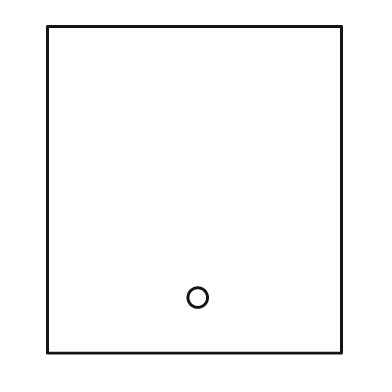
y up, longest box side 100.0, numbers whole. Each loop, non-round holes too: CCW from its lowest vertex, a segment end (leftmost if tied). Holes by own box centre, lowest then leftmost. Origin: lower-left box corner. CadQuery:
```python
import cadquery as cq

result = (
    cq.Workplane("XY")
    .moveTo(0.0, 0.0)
    .lineTo(90.0, 0.0)
    .lineTo(90.0, 100.0)
    .lineTo(0.0, 100.0)
    .close()
    .moveTo(46.0, 17.0)
    .circle(3.0)
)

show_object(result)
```